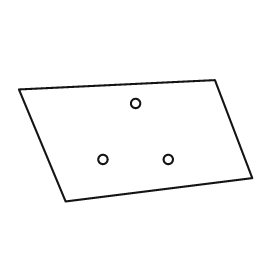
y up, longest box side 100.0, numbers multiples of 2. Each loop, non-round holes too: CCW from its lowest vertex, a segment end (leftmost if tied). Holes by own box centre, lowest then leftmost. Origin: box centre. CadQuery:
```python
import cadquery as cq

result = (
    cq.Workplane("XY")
    .moveTo(-30.0, -26.0)
    .lineTo(50.0, -16.0)
    .lineTo(34.0, 26.0)
    .lineTo(-50.0, 22.0)
    .close()
    .moveTo(-14.0, -8.0)
    .circle(2.0)
    .moveTo(14.0, -8.0)
    .circle(2.0)
    .moveTo(0.0, 16.0)
    .circle(2.0)
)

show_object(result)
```